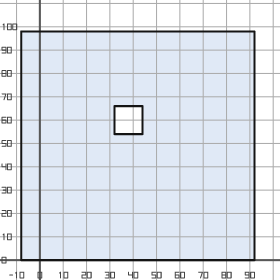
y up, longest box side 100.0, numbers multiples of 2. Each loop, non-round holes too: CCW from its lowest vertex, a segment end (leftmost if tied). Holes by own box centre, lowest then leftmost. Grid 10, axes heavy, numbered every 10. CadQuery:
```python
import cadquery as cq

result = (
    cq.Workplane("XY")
    .moveTo(-8.0, 0.0)
    .lineTo(92.0, 0.0)
    .lineTo(92.0, 98.0)
    .lineTo(-8.0, 98.0)
    .close()
    .moveTo(32.0, 54.0)
    .lineTo(44.0, 54.0)
    .lineTo(44.0, 66.0)
    .lineTo(32.0, 66.0)
    .close()
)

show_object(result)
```